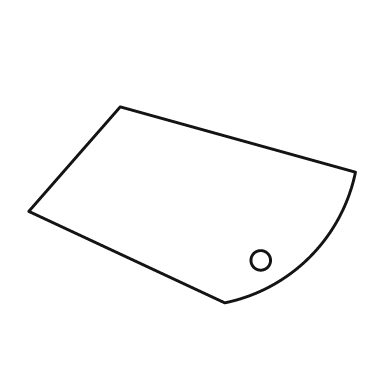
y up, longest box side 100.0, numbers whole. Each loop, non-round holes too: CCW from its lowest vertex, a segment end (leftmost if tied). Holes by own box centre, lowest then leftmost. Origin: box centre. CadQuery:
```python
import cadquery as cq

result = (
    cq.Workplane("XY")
    .moveTo(10.0, -30.0)
    .threePointArc((36.0, -16.0), (50.0, 10.0))
    .lineTo(-22.0, 30.0)
    .lineTo(-50.0, -2.0)
    .close()
    .moveTo(21.0, -17.0)
    .circle(3.0)
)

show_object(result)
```